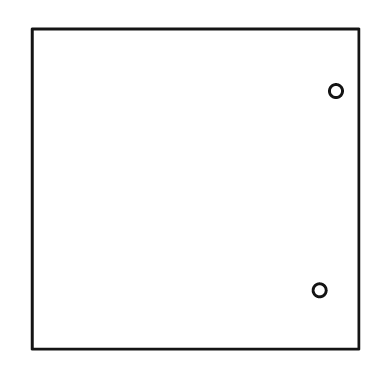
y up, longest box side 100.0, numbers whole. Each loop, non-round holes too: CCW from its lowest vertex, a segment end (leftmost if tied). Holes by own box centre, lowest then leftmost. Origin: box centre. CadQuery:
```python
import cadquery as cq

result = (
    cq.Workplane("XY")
    .moveTo(-50.0, -49.0)
    .lineTo(50.0, -49.0)
    .lineTo(50.0, 49.0)
    .lineTo(-50.0, 49.0)
    .close()
    .moveTo(38.0, -31.0)
    .circle(2.0)
    .moveTo(43.0, 30.0)
    .circle(2.0)
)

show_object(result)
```